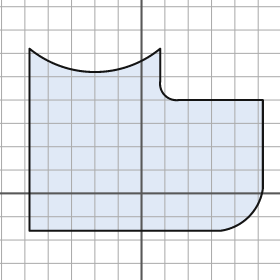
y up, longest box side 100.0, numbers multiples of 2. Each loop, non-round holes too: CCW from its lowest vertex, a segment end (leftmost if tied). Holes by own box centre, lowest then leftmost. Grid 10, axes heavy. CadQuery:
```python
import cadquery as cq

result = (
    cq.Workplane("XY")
    .moveTo(-48.0, -16.0)
    .lineTo(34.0, -16.0)
    .threePointArc((46.0, -10.0), (52.0, 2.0))
    .lineTo(52.0, 40.0)
    .lineTo(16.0, 40.0)
    .threePointArc((10.0, 42.0), (8.0, 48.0))
    .lineTo(8.0, 62.0)
    .threePointArc((-20.0, 52.0), (-48.0, 62.0))
    .close()
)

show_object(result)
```